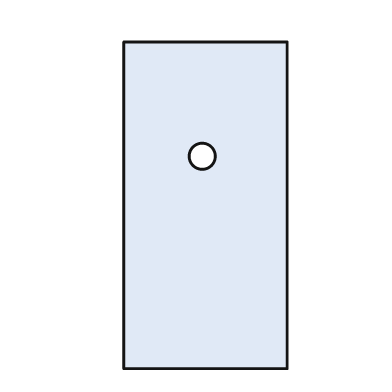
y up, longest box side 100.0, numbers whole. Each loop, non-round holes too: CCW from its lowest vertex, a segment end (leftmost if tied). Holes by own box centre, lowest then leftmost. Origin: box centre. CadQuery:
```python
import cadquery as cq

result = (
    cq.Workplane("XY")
    .moveTo(-25.0, -50.0)
    .lineTo(25.0, -50.0)
    .lineTo(25.0, 50.0)
    .lineTo(-25.0, 50.0)
    .close()
    .moveTo(-1.0, 15.0)
    .circle(4.0)
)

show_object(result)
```